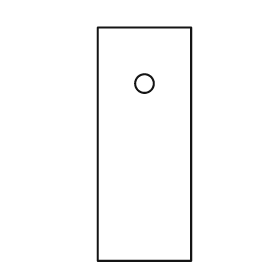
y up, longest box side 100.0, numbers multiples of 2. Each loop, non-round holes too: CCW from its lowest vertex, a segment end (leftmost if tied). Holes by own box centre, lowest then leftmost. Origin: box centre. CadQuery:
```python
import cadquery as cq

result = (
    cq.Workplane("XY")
    .moveTo(-20.0, -50.0)
    .lineTo(20.0, -50.0)
    .lineTo(20.0, 50.0)
    .lineTo(-20.0, 50.0)
    .close()
    .moveTo(0.0, 26.0)
    .circle(4.0)
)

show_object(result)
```